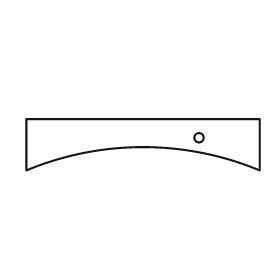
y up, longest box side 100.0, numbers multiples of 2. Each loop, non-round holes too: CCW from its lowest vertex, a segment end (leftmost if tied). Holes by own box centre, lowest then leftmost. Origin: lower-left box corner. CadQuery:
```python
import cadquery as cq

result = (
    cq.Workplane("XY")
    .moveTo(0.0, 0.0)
    .threePointArc((50.0, 10.0), (100.0, 0.0))
    .lineTo(100.0, 22.0)
    .lineTo(0.0, 22.0)
    .close()
    .moveTo(74.0, 14.0)
    .circle(2.0)
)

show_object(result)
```